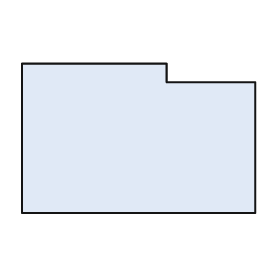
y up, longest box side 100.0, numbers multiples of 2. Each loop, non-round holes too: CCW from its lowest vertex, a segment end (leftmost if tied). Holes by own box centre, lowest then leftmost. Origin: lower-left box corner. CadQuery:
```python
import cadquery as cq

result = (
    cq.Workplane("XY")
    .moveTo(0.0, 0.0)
    .lineTo(100.0, 0.0)
    .lineTo(100.0, 56.0)
    .lineTo(62.0, 56.0)
    .lineTo(62.0, 64.0)
    .lineTo(0.0, 64.0)
    .close()
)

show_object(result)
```